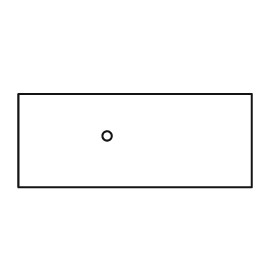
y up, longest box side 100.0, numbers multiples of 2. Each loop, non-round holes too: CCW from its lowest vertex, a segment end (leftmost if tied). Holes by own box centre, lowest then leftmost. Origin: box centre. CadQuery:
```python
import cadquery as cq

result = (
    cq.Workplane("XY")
    .moveTo(-50.0, -20.0)
    .lineTo(50.0, -20.0)
    .lineTo(50.0, 20.0)
    .lineTo(-50.0, 20.0)
    .close()
    .moveTo(-12.0, 2.0)
    .circle(2.0)
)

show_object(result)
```